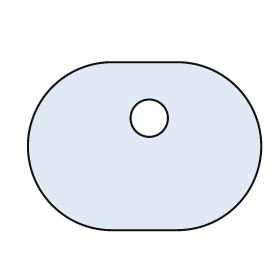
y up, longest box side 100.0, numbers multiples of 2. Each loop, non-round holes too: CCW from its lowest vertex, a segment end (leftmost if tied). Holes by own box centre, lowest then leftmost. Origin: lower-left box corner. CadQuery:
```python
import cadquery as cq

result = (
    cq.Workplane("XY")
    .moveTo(36.0, 0.0)
    .lineTo(64.0, 0.0)
    .threePointArc((100.0, 36.0), (64.0, 72.0))
    .lineTo(36.0, 72.0)
    .threePointArc((0.0, 36.0), (36.0, 0.0))
    .close()
    .moveTo(52.0, 48.0)
    .circle(8.0)
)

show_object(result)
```